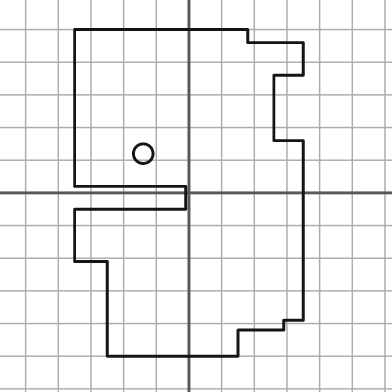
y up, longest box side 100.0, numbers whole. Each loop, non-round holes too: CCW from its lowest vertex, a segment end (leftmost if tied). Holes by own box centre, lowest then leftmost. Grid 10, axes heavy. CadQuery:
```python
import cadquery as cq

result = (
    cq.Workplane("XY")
    .moveTo(-25.0, -50.0)
    .lineTo(15.0, -50.0)
    .lineTo(15.0, -42.0)
    .lineTo(29.0, -42.0)
    .lineTo(29.0, -39.0)
    .lineTo(35.0, -39.0)
    .lineTo(35.0, 16.0)
    .lineTo(26.0, 16.0)
    .lineTo(26.0, 36.0)
    .lineTo(35.0, 36.0)
    .lineTo(35.0, 46.0)
    .lineTo(18.0, 46.0)
    .lineTo(18.0, 50.0)
    .lineTo(-35.0, 50.0)
    .lineTo(-35.0, 2.0)
    .lineTo(-1.0, 2.0)
    .lineTo(-1.0, -5.0)
    .lineTo(-35.0, -5.0)
    .lineTo(-35.0, -21.0)
    .lineTo(-25.0, -21.0)
    .close()
    .moveTo(-14.0, 12.0)
    .circle(3.0)
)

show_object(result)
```